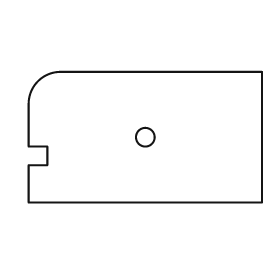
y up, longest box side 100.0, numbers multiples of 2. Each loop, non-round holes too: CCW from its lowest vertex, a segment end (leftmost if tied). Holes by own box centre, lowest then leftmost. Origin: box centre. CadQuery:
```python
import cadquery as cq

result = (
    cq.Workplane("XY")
    .moveTo(-50.0, -28.0)
    .lineTo(50.0, -28.0)
    .lineTo(50.0, 28.0)
    .lineTo(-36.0, 28.0)
    .threePointArc((-46.0, 24.0), (-50.0, 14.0))
    .lineTo(-50.0, -4.0)
    .lineTo(-42.0, -4.0)
    .lineTo(-42.0, -12.0)
    .lineTo(-50.0, -12.0)
    .close()
    .moveTo(0.0, 0.0)
    .circle(4.0)
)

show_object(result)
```